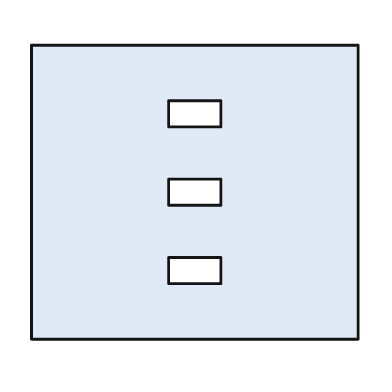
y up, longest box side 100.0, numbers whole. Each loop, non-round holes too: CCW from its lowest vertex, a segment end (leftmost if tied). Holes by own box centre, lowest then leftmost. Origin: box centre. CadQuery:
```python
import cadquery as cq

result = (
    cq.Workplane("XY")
    .moveTo(-50.0, -45.0)
    .lineTo(50.0, -45.0)
    .lineTo(50.0, 45.0)
    .lineTo(-50.0, 45.0)
    .close()
    .moveTo(-8.0, -28.0)
    .lineTo(8.0, -28.0)
    .lineTo(8.0, -20.0)
    .lineTo(-8.0, -20.0)
    .close()
    .moveTo(-8.0, -4.0)
    .lineTo(8.0, -4.0)
    .lineTo(8.0, 4.0)
    .lineTo(-8.0, 4.0)
    .close()
    .moveTo(-8.0, 20.0)
    .lineTo(8.0, 20.0)
    .lineTo(8.0, 28.0)
    .lineTo(-8.0, 28.0)
    .close()
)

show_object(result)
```